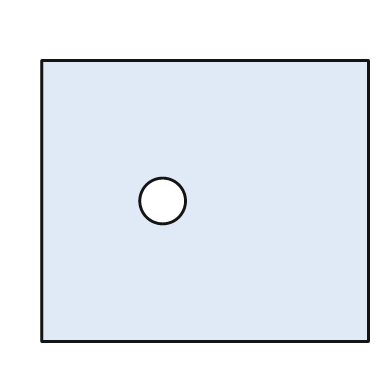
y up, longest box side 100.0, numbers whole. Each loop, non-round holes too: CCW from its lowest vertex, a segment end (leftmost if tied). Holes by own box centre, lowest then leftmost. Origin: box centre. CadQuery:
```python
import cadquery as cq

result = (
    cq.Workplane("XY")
    .moveTo(-50.0, -43.0)
    .lineTo(50.0, -43.0)
    .lineTo(50.0, 43.0)
    .lineTo(-50.0, 43.0)
    .close()
    .moveTo(-13.0, 0.0)
    .circle(7.0)
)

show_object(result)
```